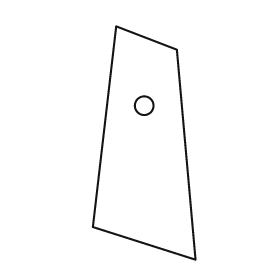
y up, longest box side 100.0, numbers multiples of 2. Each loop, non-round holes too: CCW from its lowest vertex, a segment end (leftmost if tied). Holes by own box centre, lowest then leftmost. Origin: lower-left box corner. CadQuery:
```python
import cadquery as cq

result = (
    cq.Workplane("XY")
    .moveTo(44.0, 0.0)
    .lineTo(36.0, 90.0)
    .lineTo(10.0, 100.0)
    .lineTo(0.0, 14.0)
    .close()
    .moveTo(22.0, 66.0)
    .circle(4.0)
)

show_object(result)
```